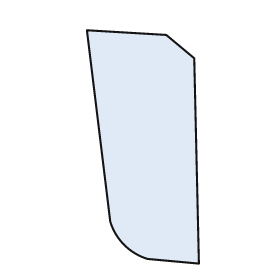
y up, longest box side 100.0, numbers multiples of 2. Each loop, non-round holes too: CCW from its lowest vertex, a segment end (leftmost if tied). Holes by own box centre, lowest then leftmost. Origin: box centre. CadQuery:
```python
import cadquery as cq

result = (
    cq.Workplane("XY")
    .moveTo(24.0, -50.0)
    .lineTo(22.0, 38.0)
    .lineTo(10.0, 48.0)
    .lineTo(-24.0, 50.0)
    .lineTo(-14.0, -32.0)
    .threePointArc((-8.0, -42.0), (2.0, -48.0))
    .close()
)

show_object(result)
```